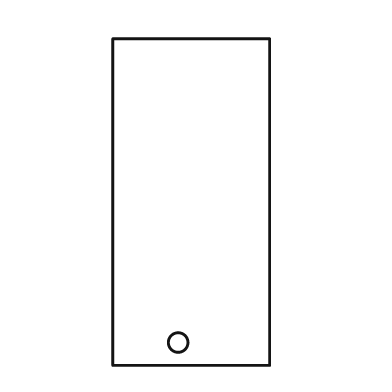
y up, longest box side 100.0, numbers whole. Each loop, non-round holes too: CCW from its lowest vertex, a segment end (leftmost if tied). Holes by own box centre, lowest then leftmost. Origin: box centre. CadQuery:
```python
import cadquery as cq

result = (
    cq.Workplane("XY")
    .moveTo(-24.0, -50.0)
    .lineTo(24.0, -50.0)
    .lineTo(24.0, 50.0)
    .lineTo(-24.0, 50.0)
    .close()
    .moveTo(-4.0, -43.0)
    .circle(3.0)
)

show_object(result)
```